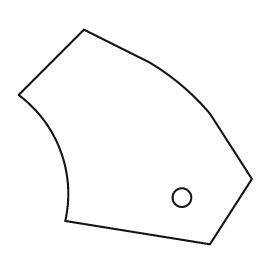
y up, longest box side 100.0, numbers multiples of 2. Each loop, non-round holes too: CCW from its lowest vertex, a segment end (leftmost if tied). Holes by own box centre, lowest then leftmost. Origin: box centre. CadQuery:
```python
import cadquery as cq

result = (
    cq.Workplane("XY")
    .moveTo(32.0, -46.0)
    .lineTo(50.0, -18.0)
    .lineTo(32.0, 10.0)
    .threePointArc((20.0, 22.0), (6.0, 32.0))
    .lineTo(-22.0, 46.0)
    .lineTo(-50.0, 18.0)
    .threePointArc((-32.0, -6.0), (-30.0, -36.0))
    .close()
    .moveTo(20.0, -26.0)
    .circle(4.0)
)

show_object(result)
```